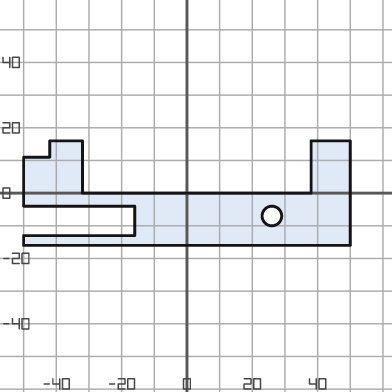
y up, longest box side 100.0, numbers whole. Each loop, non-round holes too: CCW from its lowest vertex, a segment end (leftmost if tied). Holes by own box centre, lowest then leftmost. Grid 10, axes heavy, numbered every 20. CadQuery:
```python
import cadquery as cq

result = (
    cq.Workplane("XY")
    .moveTo(-50.0, -16.0)
    .lineTo(50.0, -16.0)
    .lineTo(50.0, 16.0)
    .lineTo(38.0, 16.0)
    .lineTo(38.0, 0.0)
    .lineTo(-32.0, 0.0)
    .lineTo(-32.0, 16.0)
    .lineTo(-42.0, 16.0)
    .lineTo(-42.0, 11.0)
    .lineTo(-50.0, 11.0)
    .lineTo(-50.0, -4.0)
    .lineTo(-16.0, -4.0)
    .lineTo(-16.0, -13.0)
    .lineTo(-50.0, -13.0)
    .close()
    .moveTo(26.0, -7.0)
    .circle(3.0)
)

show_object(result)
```